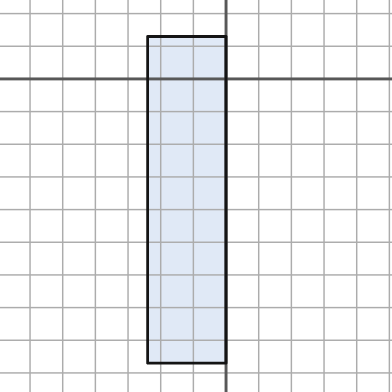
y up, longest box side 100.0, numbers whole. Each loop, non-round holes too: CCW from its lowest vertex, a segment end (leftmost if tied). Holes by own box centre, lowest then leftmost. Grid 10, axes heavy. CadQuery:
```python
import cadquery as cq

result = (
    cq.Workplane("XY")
    .moveTo(-24.0, -87.0)
    .lineTo(0.0, -87.0)
    .lineTo(0.0, 13.0)
    .lineTo(-24.0, 13.0)
    .close()
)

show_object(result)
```